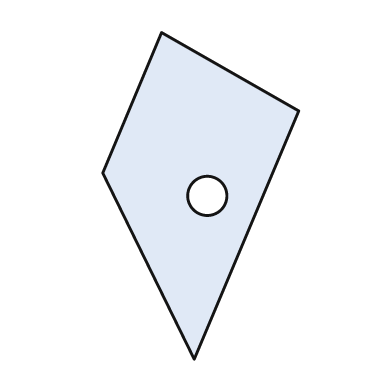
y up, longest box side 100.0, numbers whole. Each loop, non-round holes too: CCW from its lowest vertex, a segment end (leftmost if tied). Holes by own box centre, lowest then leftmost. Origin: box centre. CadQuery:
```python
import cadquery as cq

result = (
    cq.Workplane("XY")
    .moveTo(-2.0, -50.0)
    .lineTo(30.0, 26.0)
    .lineTo(-12.0, 50.0)
    .lineTo(-30.0, 7.0)
    .close()
    .moveTo(2.0, 0.0)
    .circle(6.0)
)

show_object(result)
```